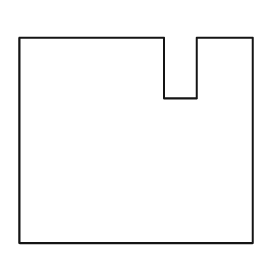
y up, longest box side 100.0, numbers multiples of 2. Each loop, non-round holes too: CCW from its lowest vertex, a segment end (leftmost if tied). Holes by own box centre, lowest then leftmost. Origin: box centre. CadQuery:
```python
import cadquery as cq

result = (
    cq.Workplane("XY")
    .moveTo(-50.0, -44.0)
    .lineTo(50.0, -44.0)
    .lineTo(50.0, 44.0)
    .lineTo(26.0, 44.0)
    .lineTo(26.0, 18.0)
    .lineTo(12.0, 18.0)
    .lineTo(12.0, 44.0)
    .lineTo(-50.0, 44.0)
    .close()
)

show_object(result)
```